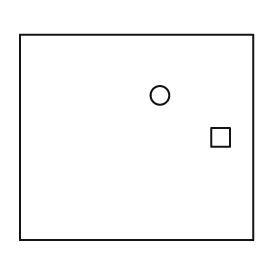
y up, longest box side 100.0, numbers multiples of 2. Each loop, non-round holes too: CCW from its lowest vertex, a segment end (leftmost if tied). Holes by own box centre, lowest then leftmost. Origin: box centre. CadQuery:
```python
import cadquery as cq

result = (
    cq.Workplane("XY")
    .moveTo(-50.0, -44.0)
    .lineTo(50.0, -44.0)
    .lineTo(50.0, 44.0)
    .lineTo(-50.0, 44.0)
    .close()
    .moveTo(32.0, -4.0)
    .lineTo(40.0, -4.0)
    .lineTo(40.0, 4.0)
    .lineTo(32.0, 4.0)
    .close()
    .moveTo(10.0, 18.0)
    .circle(4.0)
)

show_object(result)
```